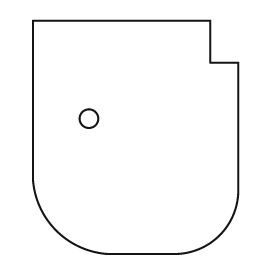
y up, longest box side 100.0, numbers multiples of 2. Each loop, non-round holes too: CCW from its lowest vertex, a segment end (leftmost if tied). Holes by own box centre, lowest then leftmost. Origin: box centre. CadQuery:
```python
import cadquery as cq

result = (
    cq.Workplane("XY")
    .moveTo(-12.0, -50.0)
    .lineTo(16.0, -50.0)
    .threePointArc((36.0, -42.0), (44.0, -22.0))
    .lineTo(44.0, 32.0)
    .lineTo(32.0, 32.0)
    .lineTo(32.0, 50.0)
    .lineTo(-44.0, 50.0)
    .lineTo(-44.0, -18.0)
    .threePointArc((-34.0, -40.0), (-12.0, -50.0))
    .close()
    .moveTo(-20.0, 8.0)
    .circle(4.0)
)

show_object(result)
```